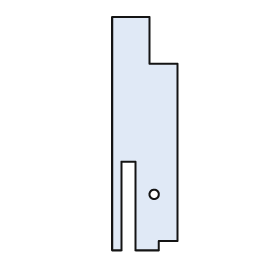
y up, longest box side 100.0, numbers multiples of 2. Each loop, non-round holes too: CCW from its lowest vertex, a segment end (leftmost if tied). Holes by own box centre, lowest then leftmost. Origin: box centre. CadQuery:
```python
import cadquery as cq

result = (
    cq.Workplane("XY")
    .moveTo(-14.0, -50.0)
    .lineTo(-10.0, -50.0)
    .lineTo(-10.0, -12.0)
    .lineTo(-4.0, -12.0)
    .lineTo(-4.0, -50.0)
    .lineTo(6.0, -50.0)
    .lineTo(6.0, -46.0)
    .lineTo(14.0, -46.0)
    .lineTo(14.0, 30.0)
    .lineTo(2.0, 30.0)
    .lineTo(2.0, 50.0)
    .lineTo(-14.0, 50.0)
    .close()
    .moveTo(4.0, -26.0)
    .circle(2.0)
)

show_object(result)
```